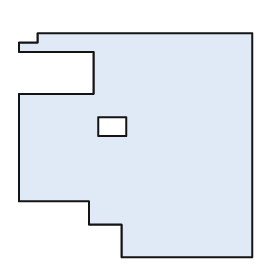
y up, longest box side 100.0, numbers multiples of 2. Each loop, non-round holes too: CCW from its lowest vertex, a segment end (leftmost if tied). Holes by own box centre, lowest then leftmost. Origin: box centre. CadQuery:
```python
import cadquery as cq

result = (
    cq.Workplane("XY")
    .moveTo(-6.0, -48.0)
    .lineTo(50.0, -48.0)
    .lineTo(50.0, 48.0)
    .lineTo(-42.0, 48.0)
    .lineTo(-42.0, 44.0)
    .lineTo(-50.0, 44.0)
    .lineTo(-50.0, 40.0)
    .lineTo(-18.0, 40.0)
    .lineTo(-18.0, 22.0)
    .lineTo(-50.0, 22.0)
    .lineTo(-50.0, -24.0)
    .lineTo(-20.0, -24.0)
    .lineTo(-20.0, -34.0)
    .lineTo(-6.0, -34.0)
    .close()
    .moveTo(-16.0, 4.0)
    .lineTo(-4.0, 4.0)
    .lineTo(-4.0, 12.0)
    .lineTo(-16.0, 12.0)
    .close()
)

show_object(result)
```